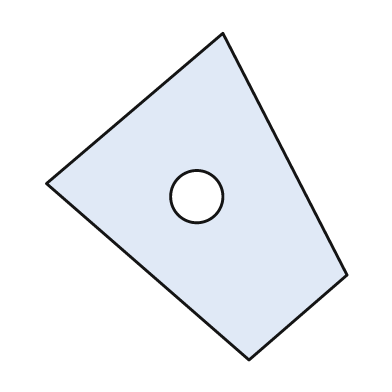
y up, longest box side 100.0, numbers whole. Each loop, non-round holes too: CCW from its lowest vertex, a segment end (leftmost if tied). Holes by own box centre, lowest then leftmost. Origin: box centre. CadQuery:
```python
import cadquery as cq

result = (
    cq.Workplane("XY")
    .moveTo(16.0, -50.0)
    .lineTo(46.0, -24.0)
    .lineTo(8.0, 50.0)
    .lineTo(-46.0, 4.0)
    .close()
    .moveTo(0.0, 0.0)
    .circle(8.0)
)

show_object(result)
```